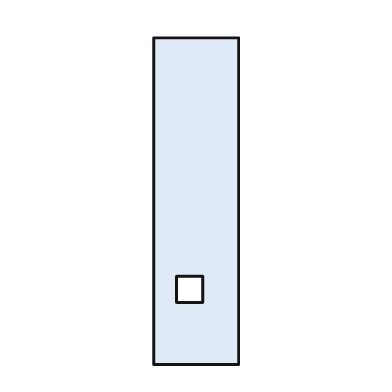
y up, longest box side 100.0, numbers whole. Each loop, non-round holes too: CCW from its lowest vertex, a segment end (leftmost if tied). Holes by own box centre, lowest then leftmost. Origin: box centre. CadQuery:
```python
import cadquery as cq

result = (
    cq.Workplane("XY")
    .moveTo(-13.0, -50.0)
    .lineTo(13.0, -50.0)
    .lineTo(13.0, 50.0)
    .lineTo(-13.0, 50.0)
    .close()
    .moveTo(-6.0, -31.0)
    .lineTo(2.0, -31.0)
    .lineTo(2.0, -23.0)
    .lineTo(-6.0, -23.0)
    .close()
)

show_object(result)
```